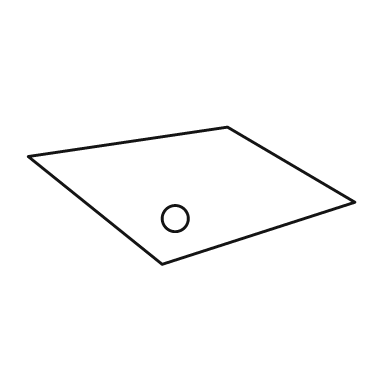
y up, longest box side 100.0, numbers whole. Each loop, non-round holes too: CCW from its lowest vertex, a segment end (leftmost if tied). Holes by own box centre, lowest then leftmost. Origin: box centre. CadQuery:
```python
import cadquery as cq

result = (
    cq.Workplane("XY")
    .moveTo(-9.0, -21.0)
    .lineTo(50.0, -2.0)
    .lineTo(11.0, 21.0)
    .lineTo(-50.0, 12.0)
    .close()
    .moveTo(-5.0, -7.0)
    .circle(4.0)
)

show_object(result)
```